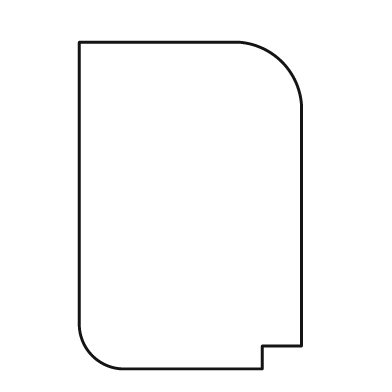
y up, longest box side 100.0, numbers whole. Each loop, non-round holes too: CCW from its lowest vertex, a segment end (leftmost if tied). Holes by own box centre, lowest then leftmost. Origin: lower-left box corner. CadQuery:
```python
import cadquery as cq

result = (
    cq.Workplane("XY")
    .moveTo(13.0, 0.0)
    .lineTo(56.0, 0.0)
    .lineTo(56.0, 7.0)
    .lineTo(68.0, 7.0)
    .lineTo(68.0, 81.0)
    .threePointArc((62.0, 94.0), (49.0, 100.0))
    .lineTo(0.0, 100.0)
    .lineTo(0.0, 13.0)
    .threePointArc((4.0, 4.0), (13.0, 0.0))
    .close()
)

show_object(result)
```